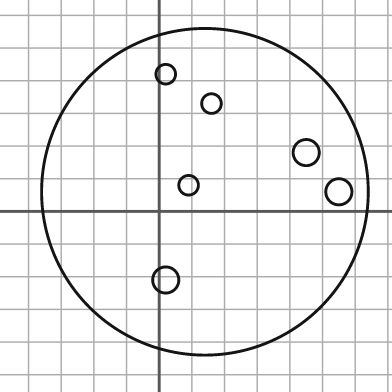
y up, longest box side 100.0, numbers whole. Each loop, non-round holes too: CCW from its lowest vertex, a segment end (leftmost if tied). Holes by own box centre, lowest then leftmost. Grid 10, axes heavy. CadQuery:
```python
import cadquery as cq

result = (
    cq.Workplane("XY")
    .moveTo(14.0, 6.0)
    .circle(50.0)
    .moveTo(2.0, -21.0)
    .circle(4.0)
    .moveTo(55.0, 6.0)
    .circle(4.0)
    .moveTo(9.0, 8.0)
    .circle(3.0)
    .moveTo(45.0, 18.0)
    .circle(4.0)
    .moveTo(16.0, 33.0)
    .circle(3.0)
    .moveTo(2.0, 42.0)
    .circle(3.0)
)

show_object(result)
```